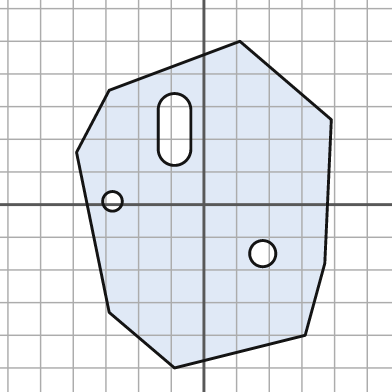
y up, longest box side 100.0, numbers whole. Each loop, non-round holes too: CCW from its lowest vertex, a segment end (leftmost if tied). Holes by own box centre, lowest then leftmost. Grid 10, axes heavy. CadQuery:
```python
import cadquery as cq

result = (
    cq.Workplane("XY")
    .moveTo(-9.0, -50.0)
    .lineTo(31.0, -40.0)
    .lineTo(37.0, -18.0)
    .lineTo(39.0, 26.0)
    .lineTo(11.0, 50.0)
    .lineTo(-29.0, 35.0)
    .lineTo(-39.0, 16.0)
    .lineTo(-29.0, -33.0)
    .close()
    .moveTo(18.0, -15.0)
    .circle(4.0)
    .moveTo(-28.0, 1.0)
    .circle(3.0)
    .moveTo(-14.0, 17.0)
    .threePointArc((-9.0, 12.0), (-4.0, 17.0))
    .lineTo(-4.0, 29.0)
    .threePointArc((-9.0, 34.0), (-14.0, 29.0))
    .close()
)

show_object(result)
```